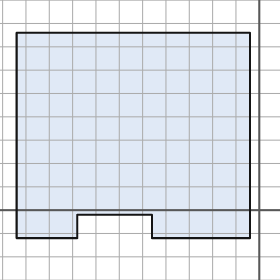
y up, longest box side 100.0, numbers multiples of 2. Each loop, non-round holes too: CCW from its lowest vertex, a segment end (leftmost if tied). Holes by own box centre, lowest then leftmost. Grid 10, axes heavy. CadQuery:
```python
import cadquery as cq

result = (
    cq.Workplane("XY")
    .moveTo(-104.0, -12.0)
    .lineTo(-78.0, -12.0)
    .lineTo(-78.0, -2.0)
    .lineTo(-46.0, -2.0)
    .lineTo(-46.0, -12.0)
    .lineTo(-4.0, -12.0)
    .lineTo(-4.0, 76.0)
    .lineTo(-104.0, 76.0)
    .close()
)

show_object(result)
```